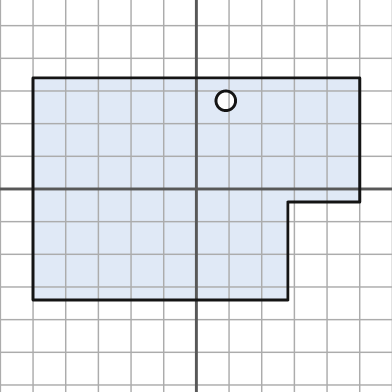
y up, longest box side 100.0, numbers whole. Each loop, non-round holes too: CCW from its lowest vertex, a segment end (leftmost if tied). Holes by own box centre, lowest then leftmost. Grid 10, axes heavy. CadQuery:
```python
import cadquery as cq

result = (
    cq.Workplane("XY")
    .moveTo(-50.0, -34.0)
    .lineTo(28.0, -34.0)
    .lineTo(28.0, -4.0)
    .lineTo(50.0, -4.0)
    .lineTo(50.0, 34.0)
    .lineTo(-50.0, 34.0)
    .close()
    .moveTo(9.0, 27.0)
    .circle(3.0)
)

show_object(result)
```